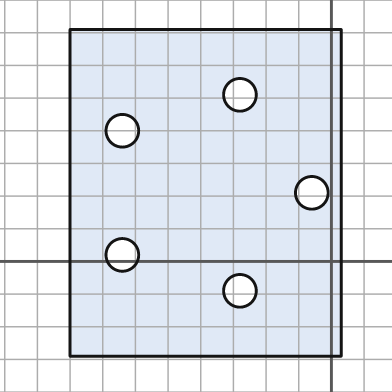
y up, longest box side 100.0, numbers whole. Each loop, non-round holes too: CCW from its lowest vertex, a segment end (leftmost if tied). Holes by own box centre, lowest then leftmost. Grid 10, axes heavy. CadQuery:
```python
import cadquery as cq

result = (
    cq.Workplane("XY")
    .moveTo(-80.0, -29.0)
    .lineTo(3.0, -29.0)
    .lineTo(3.0, 71.0)
    .lineTo(-80.0, 71.0)
    .close()
    .moveTo(-28.0, -9.0)
    .circle(5.0)
    .moveTo(-64.0, 2.0)
    .circle(5.0)
    .moveTo(-6.0, 21.0)
    .circle(5.0)
    .moveTo(-64.0, 40.0)
    .circle(5.0)
    .moveTo(-28.0, 51.0)
    .circle(5.0)
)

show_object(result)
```